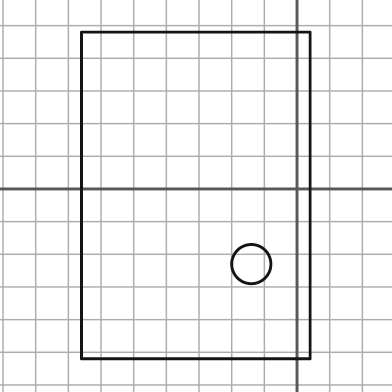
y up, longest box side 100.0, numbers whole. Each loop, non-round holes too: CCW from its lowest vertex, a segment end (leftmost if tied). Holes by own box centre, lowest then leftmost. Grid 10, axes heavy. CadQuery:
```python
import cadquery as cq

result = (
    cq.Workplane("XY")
    .moveTo(-66.0, -52.0)
    .lineTo(4.0, -52.0)
    .lineTo(4.0, 48.0)
    .lineTo(-66.0, 48.0)
    .close()
    .moveTo(-14.0, -23.0)
    .circle(6.0)
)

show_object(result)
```